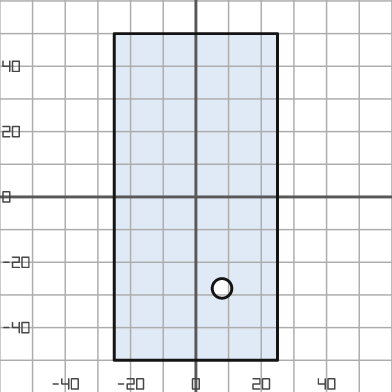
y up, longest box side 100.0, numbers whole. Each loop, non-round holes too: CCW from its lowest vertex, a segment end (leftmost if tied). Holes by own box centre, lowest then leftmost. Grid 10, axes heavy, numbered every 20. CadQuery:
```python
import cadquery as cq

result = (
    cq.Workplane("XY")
    .moveTo(-25.0, -50.0)
    .lineTo(25.0, -50.0)
    .lineTo(25.0, 50.0)
    .lineTo(-25.0, 50.0)
    .close()
    .moveTo(8.0, -28.0)
    .circle(3.0)
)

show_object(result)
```